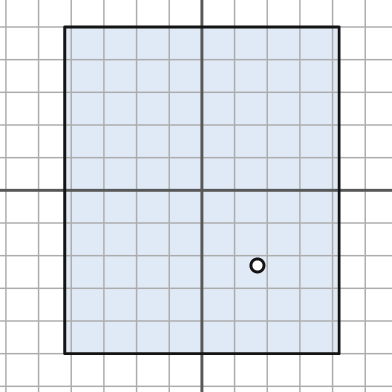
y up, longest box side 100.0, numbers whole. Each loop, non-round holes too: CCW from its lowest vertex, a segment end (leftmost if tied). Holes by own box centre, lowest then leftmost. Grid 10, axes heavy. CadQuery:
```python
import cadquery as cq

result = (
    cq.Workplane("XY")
    .moveTo(-42.0, -50.0)
    .lineTo(42.0, -50.0)
    .lineTo(42.0, 50.0)
    .lineTo(-42.0, 50.0)
    .close()
    .moveTo(17.0, -23.0)
    .circle(2.0)
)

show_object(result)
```